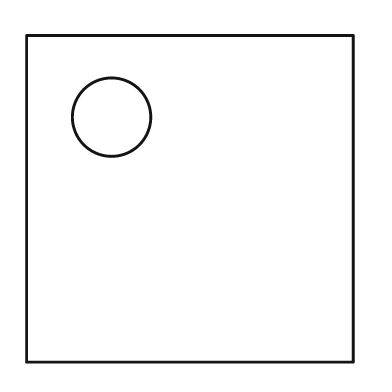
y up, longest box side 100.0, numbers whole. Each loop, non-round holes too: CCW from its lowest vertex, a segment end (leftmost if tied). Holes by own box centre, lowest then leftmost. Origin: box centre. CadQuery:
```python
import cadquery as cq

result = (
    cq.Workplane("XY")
    .moveTo(-50.0, -50.0)
    .lineTo(50.0, -50.0)
    .lineTo(50.0, 50.0)
    .lineTo(-50.0, 50.0)
    .close()
    .moveTo(-24.0, 25.0)
    .circle(12.0)
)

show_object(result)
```